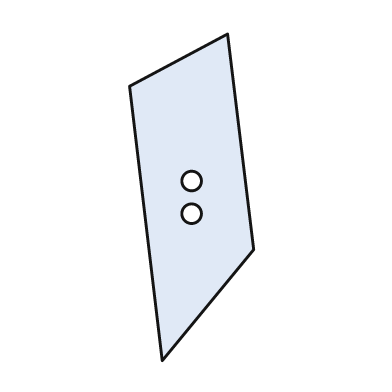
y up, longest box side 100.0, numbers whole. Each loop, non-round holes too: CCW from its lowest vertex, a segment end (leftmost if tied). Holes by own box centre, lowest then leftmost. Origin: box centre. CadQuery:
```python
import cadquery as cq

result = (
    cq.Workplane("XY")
    .moveTo(-9.0, -50.0)
    .lineTo(19.0, -16.0)
    .lineTo(11.0, 50.0)
    .lineTo(-19.0, 34.0)
    .close()
    .moveTo(0.0, -5.0)
    .circle(3.0)
    .moveTo(0.0, 5.0)
    .circle(3.0)
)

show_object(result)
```